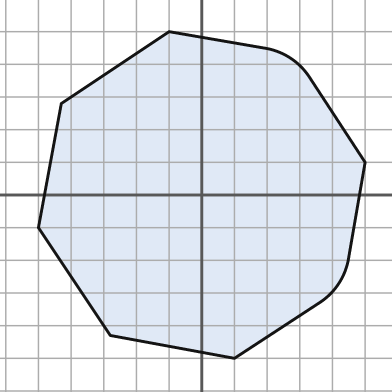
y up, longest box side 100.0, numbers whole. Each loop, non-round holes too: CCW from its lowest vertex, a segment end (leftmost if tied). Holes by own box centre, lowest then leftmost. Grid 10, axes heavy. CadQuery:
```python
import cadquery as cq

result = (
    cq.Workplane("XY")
    .moveTo(10.0, -50.0)
    .lineTo(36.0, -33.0)
    .threePointArc((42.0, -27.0), (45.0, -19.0))
    .lineTo(50.0, 10.0)
    .lineTo(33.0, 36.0)
    .threePointArc((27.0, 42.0), (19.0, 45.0))
    .lineTo(-10.0, 50.0)
    .lineTo(-43.0, 28.0)
    .lineTo(-50.0, -10.0)
    .lineTo(-28.0, -43.0)
    .close()
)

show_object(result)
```